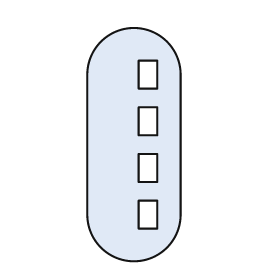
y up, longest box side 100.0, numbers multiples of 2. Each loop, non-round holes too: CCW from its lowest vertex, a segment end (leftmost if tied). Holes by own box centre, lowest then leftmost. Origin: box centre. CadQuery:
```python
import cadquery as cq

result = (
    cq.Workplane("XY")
    .moveTo(-20.0, -30.0)
    .threePointArc((0.0, -50.0), (20.0, -30.0))
    .lineTo(20.0, 30.0)
    .threePointArc((0.0, 50.0), (-20.0, 30.0))
    .close()
    .moveTo(2.0, -36.0)
    .lineTo(10.0, -36.0)
    .lineTo(10.0, -24.0)
    .lineTo(2.0, -24.0)
    .close()
    .moveTo(2.0, -16.0)
    .lineTo(10.0, -16.0)
    .lineTo(10.0, -4.0)
    .lineTo(2.0, -4.0)
    .close()
    .moveTo(2.0, 4.0)
    .lineTo(10.0, 4.0)
    .lineTo(10.0, 16.0)
    .lineTo(2.0, 16.0)
    .close()
    .moveTo(2.0, 24.0)
    .lineTo(10.0, 24.0)
    .lineTo(10.0, 36.0)
    .lineTo(2.0, 36.0)
    .close()
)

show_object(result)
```